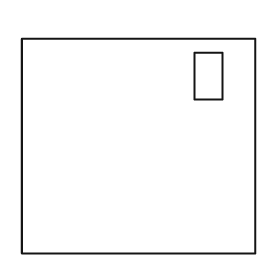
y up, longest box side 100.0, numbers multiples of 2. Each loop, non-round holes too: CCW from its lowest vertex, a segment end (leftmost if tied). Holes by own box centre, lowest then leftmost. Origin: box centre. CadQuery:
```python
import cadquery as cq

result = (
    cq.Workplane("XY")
    .moveTo(-50.0, -46.0)
    .lineTo(50.0, -46.0)
    .lineTo(50.0, 46.0)
    .lineTo(-50.0, 46.0)
    .close()
    .moveTo(24.0, 20.0)
    .lineTo(36.0, 20.0)
    .lineTo(36.0, 40.0)
    .lineTo(24.0, 40.0)
    .close()
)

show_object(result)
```